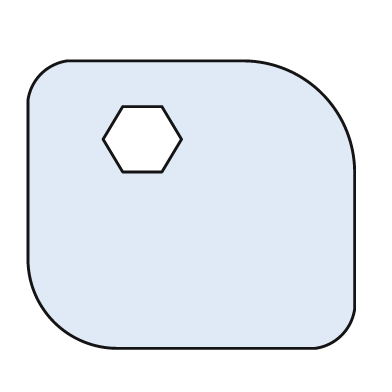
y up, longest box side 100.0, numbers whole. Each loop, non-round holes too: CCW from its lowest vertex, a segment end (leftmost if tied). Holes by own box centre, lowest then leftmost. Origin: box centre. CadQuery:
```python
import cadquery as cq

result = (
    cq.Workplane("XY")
    .moveTo(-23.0, -44.0)
    .lineTo(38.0, -44.0)
    .threePointArc((46.0, -40.0), (50.0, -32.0))
    .lineTo(50.0, 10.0)
    .threePointArc((40.0, 34.0), (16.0, 44.0))
    .lineTo(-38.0, 44.0)
    .threePointArc((-46.0, 40.0), (-50.0, 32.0))
    .lineTo(-50.0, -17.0)
    .threePointArc((-42.0, -36.0), (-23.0, -44.0))
    .close()
    .moveTo(-21.0, 10.0)
    .lineTo(-9.0, 10.0)
    .lineTo(-3.0, 20.0)
    .lineTo(-9.0, 30.0)
    .lineTo(-21.0, 30.0)
    .lineTo(-27.0, 20.0)
    .close()
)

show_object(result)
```